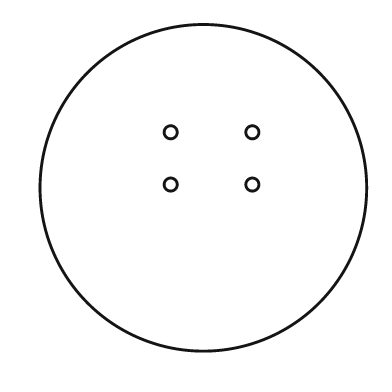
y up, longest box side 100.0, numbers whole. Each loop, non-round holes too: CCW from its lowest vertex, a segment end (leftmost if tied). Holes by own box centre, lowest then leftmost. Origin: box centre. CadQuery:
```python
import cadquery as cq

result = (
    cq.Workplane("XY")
    .moveTo(0.0, 0.0)
    .circle(50.0)
    .moveTo(-10.0, 1.0)
    .circle(2.0)
    .moveTo(15.0, 1.0)
    .circle(2.0)
    .moveTo(-10.0, 17.0)
    .circle(2.0)
    .moveTo(15.0, 17.0)
    .circle(2.0)
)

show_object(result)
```